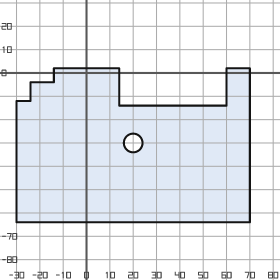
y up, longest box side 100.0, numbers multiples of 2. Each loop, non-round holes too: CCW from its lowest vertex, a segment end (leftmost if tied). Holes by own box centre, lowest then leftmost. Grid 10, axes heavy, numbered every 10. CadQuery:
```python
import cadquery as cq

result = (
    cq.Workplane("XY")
    .moveTo(-30.0, -64.0)
    .lineTo(70.0, -64.0)
    .lineTo(70.0, 2.0)
    .lineTo(60.0, 2.0)
    .lineTo(60.0, -14.0)
    .lineTo(14.0, -14.0)
    .lineTo(14.0, 2.0)
    .lineTo(-14.0, 2.0)
    .lineTo(-14.0, -4.0)
    .lineTo(-24.0, -4.0)
    .lineTo(-24.0, -12.0)
    .lineTo(-30.0, -12.0)
    .close()
    .moveTo(20.0, -30.0)
    .circle(4.0)
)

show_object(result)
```